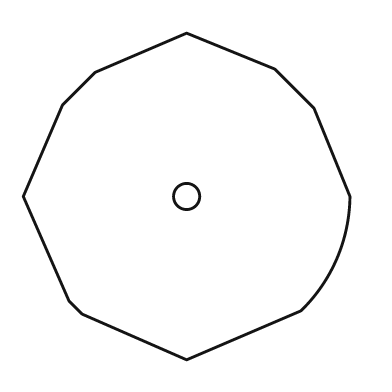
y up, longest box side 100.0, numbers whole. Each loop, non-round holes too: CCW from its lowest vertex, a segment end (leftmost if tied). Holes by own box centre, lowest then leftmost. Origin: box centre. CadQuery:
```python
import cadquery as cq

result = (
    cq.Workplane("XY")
    .moveTo(0.0, -50.0)
    .lineTo(35.0, -35.0)
    .threePointArc((46.0, -19.0), (50.0, 0.0))
    .lineTo(39.0, 27.0)
    .lineTo(27.0, 39.0)
    .lineTo(0.0, 50.0)
    .lineTo(-28.0, 38.0)
    .lineTo(-38.0, 28.0)
    .lineTo(-50.0, 0.0)
    .lineTo(-36.0, -32.0)
    .lineTo(-32.0, -36.0)
    .close()
    .moveTo(0.0, 0.0)
    .circle(4.0)
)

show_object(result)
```